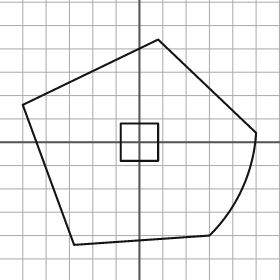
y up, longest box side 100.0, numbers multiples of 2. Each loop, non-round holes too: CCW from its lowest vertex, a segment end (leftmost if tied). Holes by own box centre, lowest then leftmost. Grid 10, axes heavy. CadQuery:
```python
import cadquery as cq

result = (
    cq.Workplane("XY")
    .moveTo(-28.0, -44.0)
    .lineTo(30.0, -40.0)
    .threePointArc((44.0, -20.0), (50.0, 4.0))
    .lineTo(8.0, 44.0)
    .lineTo(-50.0, 16.0)
    .close()
    .moveTo(-8.0, -8.0)
    .lineTo(8.0, -8.0)
    .lineTo(8.0, 8.0)
    .lineTo(-8.0, 8.0)
    .close()
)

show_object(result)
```